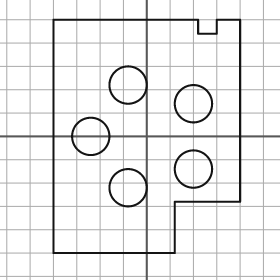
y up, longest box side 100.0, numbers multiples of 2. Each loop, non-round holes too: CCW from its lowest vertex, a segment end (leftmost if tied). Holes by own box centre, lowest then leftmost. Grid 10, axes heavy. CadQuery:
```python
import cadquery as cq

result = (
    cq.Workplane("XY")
    .moveTo(-40.0, -50.0)
    .lineTo(12.0, -50.0)
    .lineTo(12.0, -28.0)
    .lineTo(40.0, -28.0)
    .lineTo(40.0, 50.0)
    .lineTo(30.0, 50.0)
    .lineTo(30.0, 44.0)
    .lineTo(22.0, 44.0)
    .lineTo(22.0, 50.0)
    .lineTo(-40.0, 50.0)
    .close()
    .moveTo(-8.0, -22.0)
    .circle(8.0)
    .moveTo(20.0, -14.0)
    .circle(8.0)
    .moveTo(-24.0, 0.0)
    .circle(8.0)
    .moveTo(20.0, 14.0)
    .circle(8.0)
    .moveTo(-8.0, 22.0)
    .circle(8.0)
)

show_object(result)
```